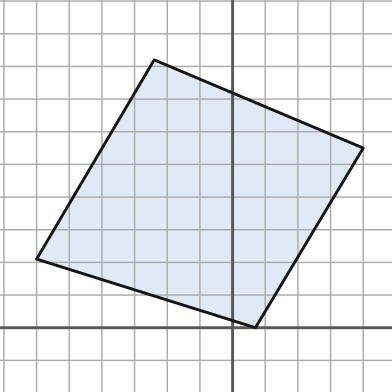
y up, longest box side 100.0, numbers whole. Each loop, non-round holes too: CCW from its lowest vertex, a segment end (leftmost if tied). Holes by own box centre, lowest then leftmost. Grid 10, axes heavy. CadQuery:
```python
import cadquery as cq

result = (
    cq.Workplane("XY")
    .moveTo(7.0, 0.0)
    .lineTo(40.0, 55.0)
    .lineTo(-24.0, 82.0)
    .lineTo(-60.0, 21.0)
    .close()
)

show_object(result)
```